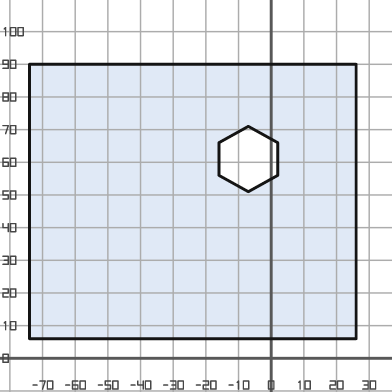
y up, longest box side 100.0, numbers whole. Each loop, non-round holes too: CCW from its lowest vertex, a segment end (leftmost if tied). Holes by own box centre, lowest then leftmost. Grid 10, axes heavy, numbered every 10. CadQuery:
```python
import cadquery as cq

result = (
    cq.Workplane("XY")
    .moveTo(-74.0, 6.0)
    .lineTo(26.0, 6.0)
    .lineTo(26.0, 90.0)
    .lineTo(-74.0, 90.0)
    .close()
    .moveTo(-7.0, 51.0)
    .lineTo(2.0, 56.0)
    .lineTo(2.0, 66.0)
    .lineTo(-7.0, 71.0)
    .lineTo(-16.0, 66.0)
    .lineTo(-16.0, 56.0)
    .close()
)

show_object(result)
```